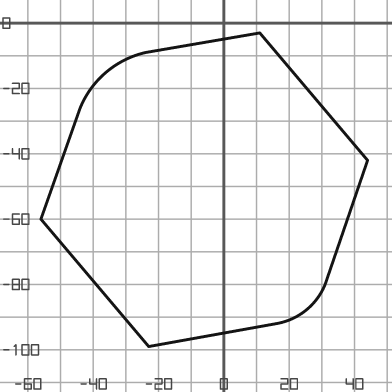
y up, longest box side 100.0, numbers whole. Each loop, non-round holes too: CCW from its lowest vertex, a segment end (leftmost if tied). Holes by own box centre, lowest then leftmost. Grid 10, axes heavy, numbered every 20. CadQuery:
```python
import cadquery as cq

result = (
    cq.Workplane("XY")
    .moveTo(-23.0, -99.0)
    .lineTo(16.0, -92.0)
    .threePointArc((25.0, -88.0), (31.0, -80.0))
    .lineTo(44.0, -42.0)
    .lineTo(11.0, -3.0)
    .lineTo(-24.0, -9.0)
    .threePointArc((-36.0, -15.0), (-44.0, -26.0))
    .lineTo(-56.0, -60.0)
    .close()
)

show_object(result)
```